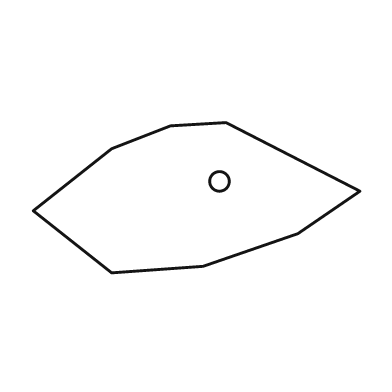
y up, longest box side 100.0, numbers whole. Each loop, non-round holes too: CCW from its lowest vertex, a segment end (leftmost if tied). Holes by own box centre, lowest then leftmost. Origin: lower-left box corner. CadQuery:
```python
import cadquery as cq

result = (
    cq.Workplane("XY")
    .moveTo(24.0, 0.0)
    .lineTo(52.0, 2.0)
    .lineTo(81.0, 12.0)
    .lineTo(100.0, 25.0)
    .lineTo(59.0, 46.0)
    .lineTo(42.0, 45.0)
    .lineTo(24.0, 38.0)
    .lineTo(0.0, 19.0)
    .close()
    .moveTo(57.0, 28.0)
    .circle(3.0)
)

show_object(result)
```